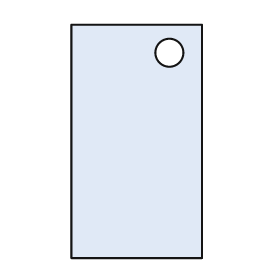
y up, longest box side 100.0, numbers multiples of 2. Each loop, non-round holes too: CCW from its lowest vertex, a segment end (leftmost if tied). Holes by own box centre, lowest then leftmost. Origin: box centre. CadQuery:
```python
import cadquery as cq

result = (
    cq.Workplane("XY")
    .moveTo(-28.0, -50.0)
    .lineTo(28.0, -50.0)
    .lineTo(28.0, 50.0)
    .lineTo(-28.0, 50.0)
    .close()
    .moveTo(14.0, 38.0)
    .circle(6.0)
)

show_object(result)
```